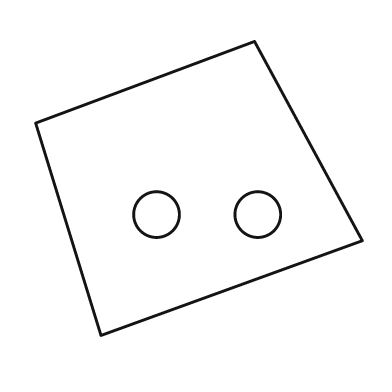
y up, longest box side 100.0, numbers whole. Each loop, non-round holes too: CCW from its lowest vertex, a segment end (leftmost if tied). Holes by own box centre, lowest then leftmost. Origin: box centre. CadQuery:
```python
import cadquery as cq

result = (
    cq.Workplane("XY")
    .moveTo(-30.0, -45.0)
    .lineTo(50.0, -16.0)
    .lineTo(17.0, 45.0)
    .lineTo(-50.0, 20.0)
    .close()
    .moveTo(-13.0, -8.0)
    .circle(7.0)
    .moveTo(18.0, -8.0)
    .circle(7.0)
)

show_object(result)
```